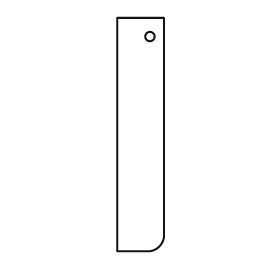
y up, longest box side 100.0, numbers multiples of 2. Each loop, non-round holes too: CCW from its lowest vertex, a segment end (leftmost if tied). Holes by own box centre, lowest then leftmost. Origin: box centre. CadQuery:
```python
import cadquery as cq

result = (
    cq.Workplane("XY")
    .moveTo(-10.0, -50.0)
    .lineTo(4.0, -50.0)
    .threePointArc((8.0, -48.0), (10.0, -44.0))
    .lineTo(10.0, 50.0)
    .lineTo(-10.0, 50.0)
    .close()
    .moveTo(4.0, 42.0)
    .circle(2.0)
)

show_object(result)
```